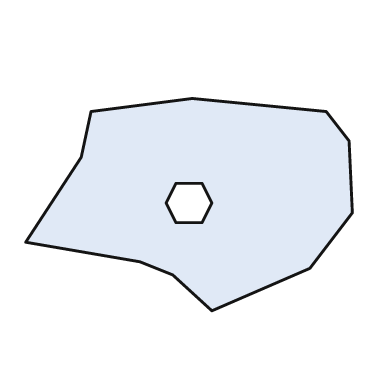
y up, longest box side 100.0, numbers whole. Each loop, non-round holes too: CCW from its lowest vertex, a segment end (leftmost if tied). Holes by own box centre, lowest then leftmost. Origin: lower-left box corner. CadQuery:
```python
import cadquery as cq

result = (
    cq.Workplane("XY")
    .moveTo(57.0, 0.0)
    .lineTo(87.0, 13.0)
    .lineTo(100.0, 30.0)
    .lineTo(99.0, 52.0)
    .lineTo(92.0, 61.0)
    .lineTo(51.0, 65.0)
    .lineTo(20.0, 61.0)
    .lineTo(17.0, 47.0)
    .lineTo(0.0, 21.0)
    .lineTo(35.0, 15.0)
    .lineTo(45.0, 11.0)
    .close()
    .moveTo(46.0, 27.0)
    .lineTo(54.0, 27.0)
    .lineTo(57.0, 33.0)
    .lineTo(54.0, 39.0)
    .lineTo(46.0, 39.0)
    .lineTo(43.0, 33.0)
    .close()
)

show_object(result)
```